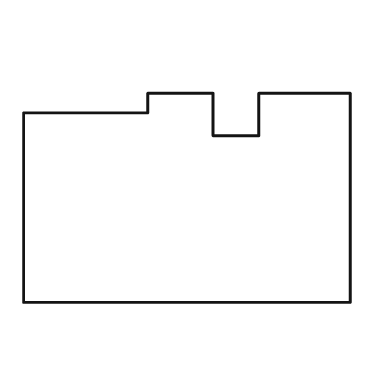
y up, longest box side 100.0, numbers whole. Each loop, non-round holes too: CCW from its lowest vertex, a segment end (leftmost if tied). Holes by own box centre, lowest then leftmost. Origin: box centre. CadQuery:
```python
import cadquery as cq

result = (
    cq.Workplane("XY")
    .moveTo(-50.0, -32.0)
    .lineTo(50.0, -32.0)
    .lineTo(50.0, 32.0)
    .lineTo(22.0, 32.0)
    .lineTo(22.0, 19.0)
    .lineTo(8.0, 19.0)
    .lineTo(8.0, 32.0)
    .lineTo(-12.0, 32.0)
    .lineTo(-12.0, 26.0)
    .lineTo(-50.0, 26.0)
    .close()
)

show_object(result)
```